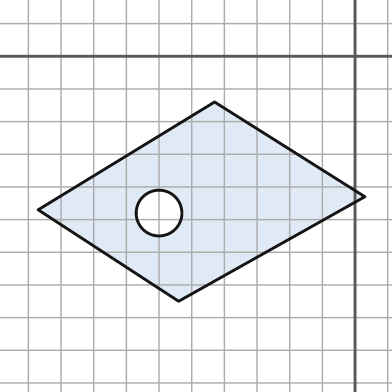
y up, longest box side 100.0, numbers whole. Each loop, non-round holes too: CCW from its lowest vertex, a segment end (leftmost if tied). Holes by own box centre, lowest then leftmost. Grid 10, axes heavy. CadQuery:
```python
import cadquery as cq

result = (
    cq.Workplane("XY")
    .moveTo(-54.0, -75.0)
    .lineTo(3.0, -43.0)
    .lineTo(-43.0, -14.0)
    .lineTo(-97.0, -47.0)
    .close()
    .moveTo(-60.0, -48.0)
    .circle(7.0)
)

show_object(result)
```